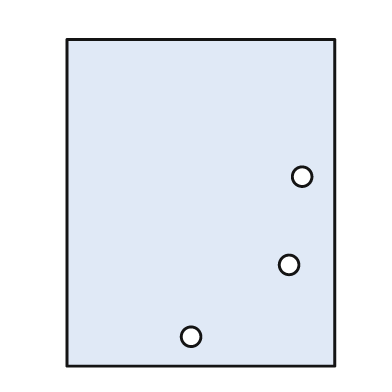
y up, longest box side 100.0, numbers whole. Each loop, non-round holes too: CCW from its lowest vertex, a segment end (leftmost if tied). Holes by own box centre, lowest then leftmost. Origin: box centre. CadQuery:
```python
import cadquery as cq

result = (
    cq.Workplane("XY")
    .moveTo(-41.0, -50.0)
    .lineTo(41.0, -50.0)
    .lineTo(41.0, 50.0)
    .lineTo(-41.0, 50.0)
    .close()
    .moveTo(-3.0, -41.0)
    .circle(3.0)
    .moveTo(27.0, -19.0)
    .circle(3.0)
    .moveTo(31.0, 8.0)
    .circle(3.0)
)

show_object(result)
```